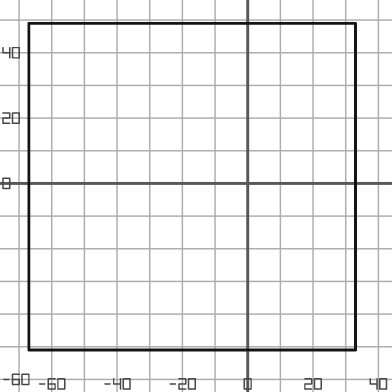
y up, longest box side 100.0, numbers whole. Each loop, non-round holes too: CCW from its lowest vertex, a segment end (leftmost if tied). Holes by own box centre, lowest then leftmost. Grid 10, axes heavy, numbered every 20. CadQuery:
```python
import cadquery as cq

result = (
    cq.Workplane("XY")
    .moveTo(-67.0, -51.0)
    .lineTo(33.0, -51.0)
    .lineTo(33.0, 49.0)
    .lineTo(-67.0, 49.0)
    .close()
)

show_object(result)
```